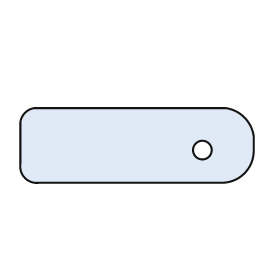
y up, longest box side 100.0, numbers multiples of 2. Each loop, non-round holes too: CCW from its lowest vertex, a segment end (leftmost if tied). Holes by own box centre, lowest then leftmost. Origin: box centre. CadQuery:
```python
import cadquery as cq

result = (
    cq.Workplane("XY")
    .moveTo(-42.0, -16.0)
    .lineTo(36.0, -16.0)
    .threePointArc((46.0, -12.0), (50.0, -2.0))
    .lineTo(50.0, 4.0)
    .threePointArc((46.0, 12.0), (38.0, 16.0))
    .lineTo(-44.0, 16.0)
    .threePointArc((-48.0, 14.0), (-50.0, 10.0))
    .lineTo(-50.0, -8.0)
    .threePointArc((-48.0, -14.0), (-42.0, -16.0))
    .close()
    .moveTo(28.0, -2.0)
    .circle(4.0)
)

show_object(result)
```